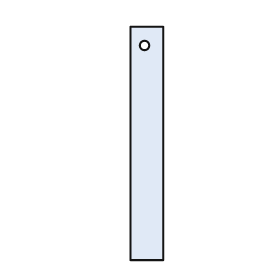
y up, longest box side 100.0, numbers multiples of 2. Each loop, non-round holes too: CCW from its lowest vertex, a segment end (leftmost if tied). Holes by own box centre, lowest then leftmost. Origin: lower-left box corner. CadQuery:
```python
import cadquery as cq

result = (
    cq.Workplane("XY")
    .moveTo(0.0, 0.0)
    .lineTo(14.0, 0.0)
    .lineTo(14.0, 100.0)
    .lineTo(0.0, 100.0)
    .close()
    .moveTo(6.0, 92.0)
    .circle(2.0)
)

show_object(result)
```